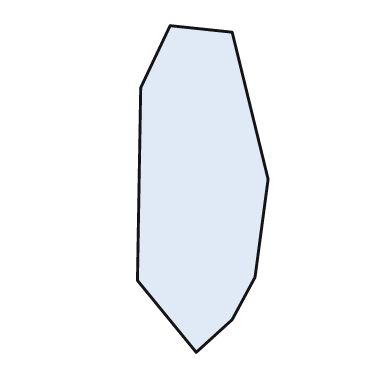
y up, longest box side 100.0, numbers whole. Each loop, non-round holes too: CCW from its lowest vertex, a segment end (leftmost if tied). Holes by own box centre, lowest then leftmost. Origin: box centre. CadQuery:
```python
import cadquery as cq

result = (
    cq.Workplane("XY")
    .moveTo(-2.0, -50.0)
    .lineTo(9.0, -40.0)
    .lineTo(16.0, -27.0)
    .lineTo(20.0, 3.0)
    .lineTo(9.0, 48.0)
    .lineTo(-10.0, 50.0)
    .lineTo(-19.0, 31.0)
    .lineTo(-20.0, -28.0)
    .close()
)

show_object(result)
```